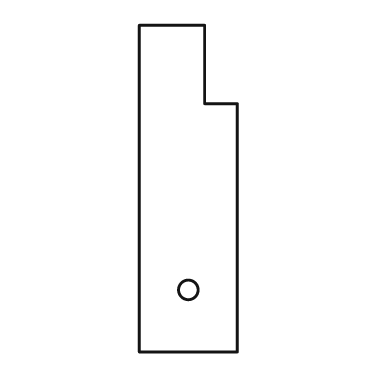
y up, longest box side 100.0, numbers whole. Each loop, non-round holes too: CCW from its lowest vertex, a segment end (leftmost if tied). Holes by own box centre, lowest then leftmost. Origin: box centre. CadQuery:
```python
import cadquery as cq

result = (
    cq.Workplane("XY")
    .moveTo(-15.0, -50.0)
    .lineTo(15.0, -50.0)
    .lineTo(15.0, 26.0)
    .lineTo(5.0, 26.0)
    .lineTo(5.0, 50.0)
    .lineTo(-15.0, 50.0)
    .close()
    .moveTo(0.0, -31.0)
    .circle(3.0)
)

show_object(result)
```